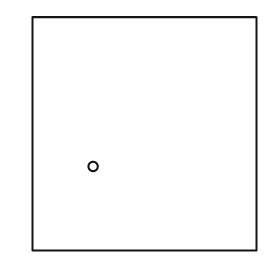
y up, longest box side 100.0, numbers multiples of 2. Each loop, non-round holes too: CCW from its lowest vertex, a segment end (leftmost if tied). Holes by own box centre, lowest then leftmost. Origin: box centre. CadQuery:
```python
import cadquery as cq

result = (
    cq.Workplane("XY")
    .moveTo(-48.0, -50.0)
    .lineTo(48.0, -50.0)
    .lineTo(48.0, 50.0)
    .lineTo(-48.0, 50.0)
    .close()
    .moveTo(-22.0, -14.0)
    .circle(2.0)
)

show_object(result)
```